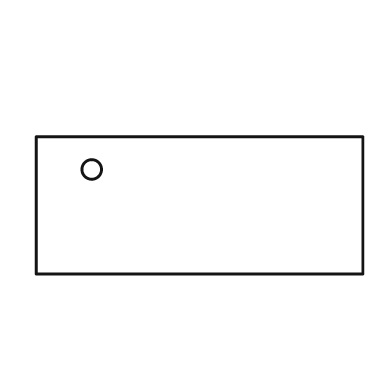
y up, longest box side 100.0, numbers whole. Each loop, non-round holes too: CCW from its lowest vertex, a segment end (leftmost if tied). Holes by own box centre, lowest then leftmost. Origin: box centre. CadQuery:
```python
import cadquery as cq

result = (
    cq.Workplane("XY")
    .moveTo(-50.0, -21.0)
    .lineTo(50.0, -21.0)
    .lineTo(50.0, 21.0)
    .lineTo(-50.0, 21.0)
    .close()
    .moveTo(-33.0, 11.0)
    .circle(3.0)
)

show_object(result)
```